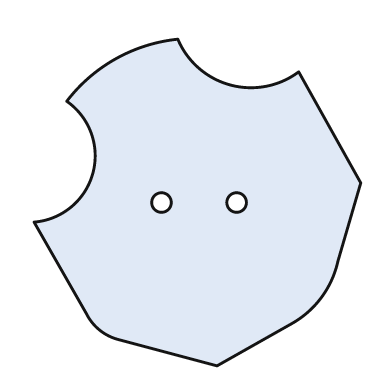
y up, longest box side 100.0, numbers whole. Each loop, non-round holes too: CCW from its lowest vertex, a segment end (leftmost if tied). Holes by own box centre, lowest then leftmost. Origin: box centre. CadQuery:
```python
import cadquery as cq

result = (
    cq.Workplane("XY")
    .moveTo(6.0, -50.0)
    .lineTo(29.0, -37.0)
    .threePointArc((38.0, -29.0), (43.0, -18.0))
    .lineTo(50.0, 6.0)
    .lineTo(31.0, 40.0)
    .threePointArc((10.0, 36.0), (-6.0, 50.0))
    .threePointArc((-25.0, 44.0), (-40.0, 31.0))
    .threePointArc((-32.0, 9.0), (-50.0, -6.0))
    .lineTo(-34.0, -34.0)
    .threePointArc((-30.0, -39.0), (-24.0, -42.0))
    .close()
    .moveTo(-11.0, 0.0)
    .circle(3.0)
    .moveTo(12.0, 0.0)
    .circle(3.0)
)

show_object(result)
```